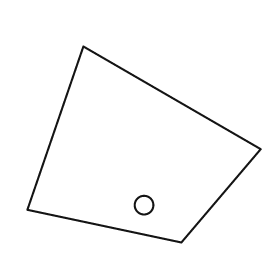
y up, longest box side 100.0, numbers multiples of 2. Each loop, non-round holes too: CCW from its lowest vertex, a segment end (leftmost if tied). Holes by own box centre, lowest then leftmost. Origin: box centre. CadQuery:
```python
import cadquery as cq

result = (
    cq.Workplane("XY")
    .moveTo(16.0, -42.0)
    .lineTo(50.0, -2.0)
    .lineTo(-26.0, 42.0)
    .lineTo(-50.0, -28.0)
    .close()
    .moveTo(0.0, -26.0)
    .circle(4.0)
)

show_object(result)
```